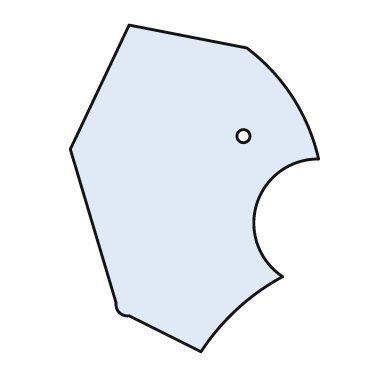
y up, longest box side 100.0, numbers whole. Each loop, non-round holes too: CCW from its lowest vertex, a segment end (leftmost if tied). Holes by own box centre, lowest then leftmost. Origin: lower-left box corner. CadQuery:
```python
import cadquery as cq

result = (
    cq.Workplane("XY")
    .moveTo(40.0, 0.0)
    .threePointArc((51.0, 13.0), (65.0, 23.0))
    .threePointArc((57.0, 45.0), (76.0, 59.0))
    .threePointArc((68.0, 78.0), (54.0, 93.0))
    .lineTo(18.0, 100.0)
    .lineTo(0.0, 62.0)
    .lineTo(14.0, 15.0)
    .threePointArc((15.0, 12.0), (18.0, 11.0))
    .close()
    .moveTo(53.0, 66.0)
    .circle(2.0)
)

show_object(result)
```